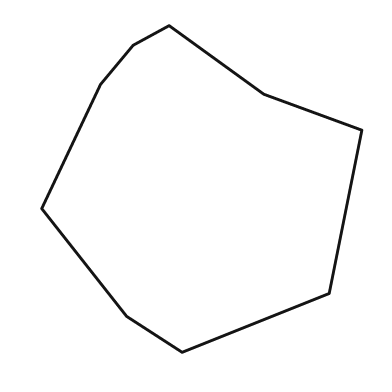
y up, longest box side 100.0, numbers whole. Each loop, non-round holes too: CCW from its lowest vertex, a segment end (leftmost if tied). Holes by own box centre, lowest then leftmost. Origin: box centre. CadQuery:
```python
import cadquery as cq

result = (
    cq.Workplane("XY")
    .moveTo(-6.0, -50.0)
    .lineTo(39.0, -32.0)
    .lineTo(49.0, 18.0)
    .lineTo(19.0, 29.0)
    .lineTo(-10.0, 50.0)
    .lineTo(-21.0, 44.0)
    .lineTo(-31.0, 32.0)
    .lineTo(-49.0, -6.0)
    .lineTo(-23.0, -39.0)
    .close()
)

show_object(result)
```